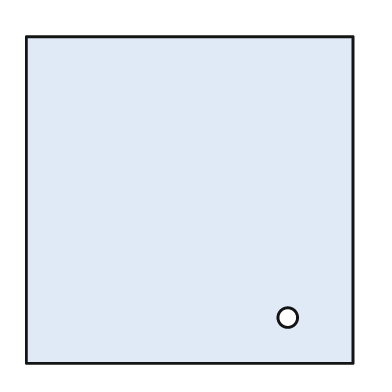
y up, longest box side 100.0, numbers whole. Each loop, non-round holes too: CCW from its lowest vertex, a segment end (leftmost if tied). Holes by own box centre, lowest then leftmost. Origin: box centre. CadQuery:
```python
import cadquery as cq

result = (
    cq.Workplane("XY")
    .moveTo(-50.0, -50.0)
    .lineTo(50.0, -50.0)
    .lineTo(50.0, 50.0)
    .lineTo(-50.0, 50.0)
    .close()
    .moveTo(30.0, -36.0)
    .circle(3.0)
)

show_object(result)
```